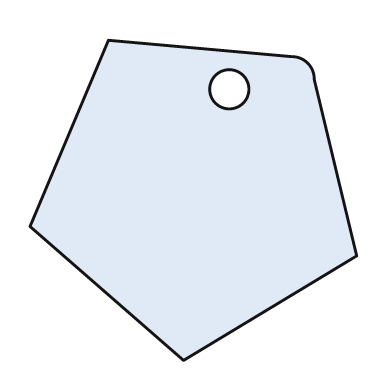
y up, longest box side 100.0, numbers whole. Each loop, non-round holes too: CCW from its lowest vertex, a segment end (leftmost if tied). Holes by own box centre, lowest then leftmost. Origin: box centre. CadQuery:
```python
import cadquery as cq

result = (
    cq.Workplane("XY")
    .moveTo(-3.0, -49.0)
    .lineTo(50.0, -17.0)
    .lineTo(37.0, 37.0)
    .threePointArc((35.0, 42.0), (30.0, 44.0))
    .lineTo(-26.0, 49.0)
    .lineTo(-50.0, -8.0)
    .close()
    .moveTo(11.0, 34.0)
    .circle(6.0)
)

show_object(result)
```